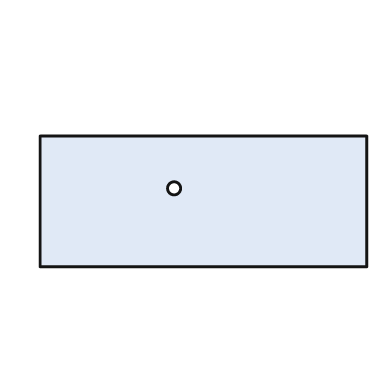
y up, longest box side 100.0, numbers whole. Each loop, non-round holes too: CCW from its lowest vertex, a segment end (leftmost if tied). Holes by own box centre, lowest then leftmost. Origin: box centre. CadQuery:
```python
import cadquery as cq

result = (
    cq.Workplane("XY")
    .moveTo(-50.0, -20.0)
    .lineTo(50.0, -20.0)
    .lineTo(50.0, 20.0)
    .lineTo(-50.0, 20.0)
    .close()
    .moveTo(-9.0, 4.0)
    .circle(2.0)
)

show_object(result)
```